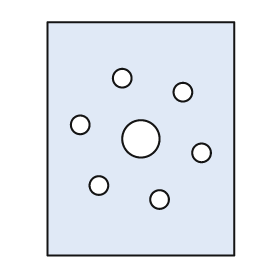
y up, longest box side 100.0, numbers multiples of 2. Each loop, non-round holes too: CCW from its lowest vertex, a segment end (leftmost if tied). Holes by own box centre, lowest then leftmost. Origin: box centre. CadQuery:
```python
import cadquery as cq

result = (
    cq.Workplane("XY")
    .moveTo(-40.0, -50.0)
    .lineTo(40.0, -50.0)
    .lineTo(40.0, 50.0)
    .lineTo(-40.0, 50.0)
    .close()
    .moveTo(8.0, -26.0)
    .circle(4.0)
    .moveTo(-18.0, -20.0)
    .circle(4.0)
    .moveTo(26.0, -6.0)
    .circle(4.0)
    .moveTo(0.0, 0.0)
    .circle(8.0)
    .moveTo(-26.0, 6.0)
    .circle(4.0)
    .moveTo(18.0, 20.0)
    .circle(4.0)
    .moveTo(-8.0, 26.0)
    .circle(4.0)
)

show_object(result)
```